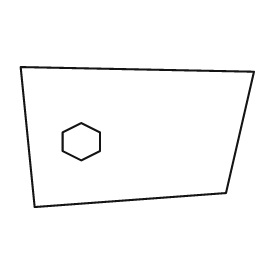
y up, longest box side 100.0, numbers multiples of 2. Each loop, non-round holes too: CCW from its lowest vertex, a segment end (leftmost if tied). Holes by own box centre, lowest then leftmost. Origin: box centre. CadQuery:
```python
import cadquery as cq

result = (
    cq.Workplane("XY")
    .moveTo(-44.0, -30.0)
    .lineTo(38.0, -24.0)
    .lineTo(50.0, 28.0)
    .lineTo(-50.0, 30.0)
    .close()
    .moveTo(-24.0, -10.0)
    .lineTo(-16.0, -6.0)
    .lineTo(-16.0, 2.0)
    .lineTo(-24.0, 6.0)
    .lineTo(-32.0, 2.0)
    .lineTo(-32.0, -6.0)
    .close()
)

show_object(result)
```